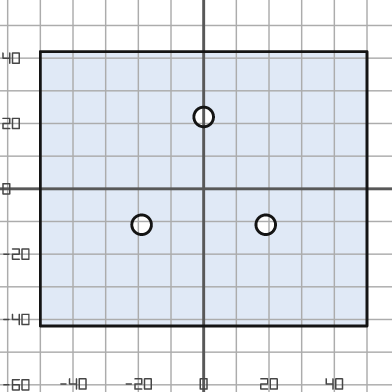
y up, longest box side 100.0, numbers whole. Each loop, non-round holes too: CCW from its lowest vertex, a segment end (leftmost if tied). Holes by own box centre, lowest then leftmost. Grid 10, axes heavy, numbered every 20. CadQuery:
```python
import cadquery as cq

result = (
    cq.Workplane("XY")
    .moveTo(-50.0, -42.0)
    .lineTo(50.0, -42.0)
    .lineTo(50.0, 42.0)
    .lineTo(-50.0, 42.0)
    .close()
    .moveTo(-19.0, -11.0)
    .circle(3.0)
    .moveTo(19.0, -11.0)
    .circle(3.0)
    .moveTo(0.0, 22.0)
    .circle(3.0)
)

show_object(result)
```